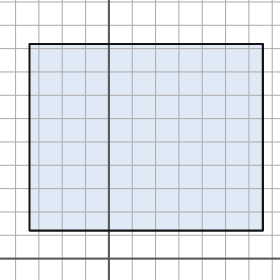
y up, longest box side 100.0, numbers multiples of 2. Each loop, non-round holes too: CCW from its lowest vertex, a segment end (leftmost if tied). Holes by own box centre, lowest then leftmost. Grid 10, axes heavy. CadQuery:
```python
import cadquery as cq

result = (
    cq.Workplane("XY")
    .moveTo(-34.0, 12.0)
    .lineTo(66.0, 12.0)
    .lineTo(66.0, 92.0)
    .lineTo(-34.0, 92.0)
    .close()
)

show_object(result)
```